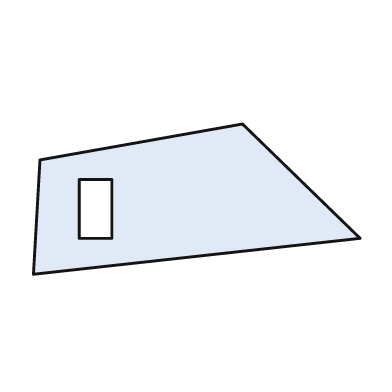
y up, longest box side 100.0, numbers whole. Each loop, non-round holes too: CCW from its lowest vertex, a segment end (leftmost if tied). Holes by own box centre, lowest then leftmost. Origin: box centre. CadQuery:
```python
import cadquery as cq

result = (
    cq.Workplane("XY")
    .moveTo(-50.0, -23.0)
    .lineTo(50.0, -12.0)
    .lineTo(14.0, 23.0)
    .lineTo(-48.0, 12.0)
    .close()
    .moveTo(-36.0, -12.0)
    .lineTo(-26.0, -12.0)
    .lineTo(-26.0, 6.0)
    .lineTo(-36.0, 6.0)
    .close()
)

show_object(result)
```